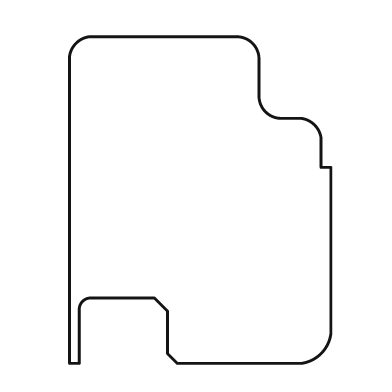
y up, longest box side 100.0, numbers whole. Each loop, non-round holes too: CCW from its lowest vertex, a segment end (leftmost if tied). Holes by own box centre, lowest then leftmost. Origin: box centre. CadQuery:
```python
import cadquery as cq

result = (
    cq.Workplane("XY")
    .moveTo(-40.0, -50.0)
    .lineTo(-37.0, -50.0)
    .lineTo(-37.0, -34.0)
    .threePointArc((-36.0, -31.0), (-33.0, -30.0))
    .lineTo(-14.0, -30.0)
    .lineTo(-10.0, -34.0)
    .lineTo(-10.0, -47.0)
    .lineTo(-7.0, -50.0)
    .lineTo(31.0, -50.0)
    .threePointArc((37.0, -47.0), (40.0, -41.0))
    .lineTo(40.0, 10.0)
    .lineTo(37.0, 10.0)
    .lineTo(37.0, 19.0)
    .threePointArc((35.0, 23.0), (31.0, 25.0))
    .lineTo(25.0, 25.0)
    .threePointArc((20.0, 27.0), (18.0, 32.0))
    .lineTo(18.0, 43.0)
    .threePointArc((16.0, 48.0), (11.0, 50.0))
    .lineTo(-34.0, 50.0)
    .threePointArc((-38.0, 48.0), (-40.0, 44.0))
    .close()
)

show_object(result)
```